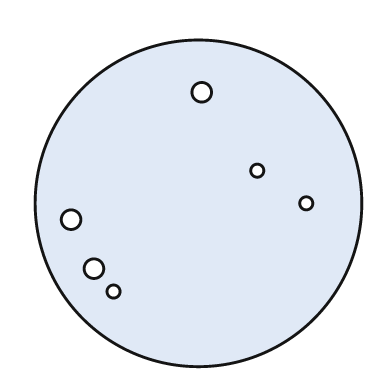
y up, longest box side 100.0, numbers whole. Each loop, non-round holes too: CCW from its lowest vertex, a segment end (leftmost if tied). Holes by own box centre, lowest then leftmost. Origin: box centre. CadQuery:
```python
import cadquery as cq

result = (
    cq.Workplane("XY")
    .moveTo(0.0, 0.0)
    .circle(50.0)
    .moveTo(-26.0, -27.0)
    .circle(2.0)
    .moveTo(-32.0, -20.0)
    .circle(3.0)
    .moveTo(-39.0, -5.0)
    .circle(3.0)
    .moveTo(33.0, 0.0)
    .circle(2.0)
    .moveTo(18.0, 10.0)
    .circle(2.0)
    .moveTo(1.0, 34.0)
    .circle(3.0)
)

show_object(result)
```